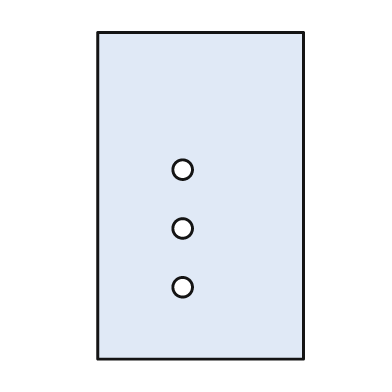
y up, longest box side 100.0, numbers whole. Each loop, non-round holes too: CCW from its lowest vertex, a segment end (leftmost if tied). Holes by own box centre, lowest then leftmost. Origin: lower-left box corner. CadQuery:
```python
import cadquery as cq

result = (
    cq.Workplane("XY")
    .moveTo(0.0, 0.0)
    .lineTo(63.0, 0.0)
    .lineTo(63.0, 100.0)
    .lineTo(0.0, 100.0)
    .close()
    .moveTo(26.0, 22.0)
    .circle(3.0)
    .moveTo(26.0, 40.0)
    .circle(3.0)
    .moveTo(26.0, 58.0)
    .circle(3.0)
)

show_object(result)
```